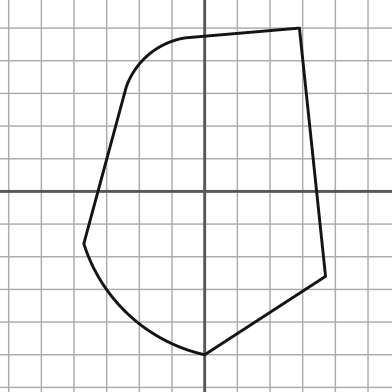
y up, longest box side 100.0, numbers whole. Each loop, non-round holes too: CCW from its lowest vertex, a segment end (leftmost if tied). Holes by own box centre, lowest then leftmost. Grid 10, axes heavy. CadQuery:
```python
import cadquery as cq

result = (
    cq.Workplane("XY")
    .moveTo(0.0, -50.0)
    .lineTo(37.0, -26.0)
    .lineTo(29.0, 50.0)
    .lineTo(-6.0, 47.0)
    .threePointArc((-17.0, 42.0), (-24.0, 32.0))
    .lineTo(-37.0, -16.0)
    .threePointArc((-23.0, -38.0), (0.0, -50.0))
    .close()
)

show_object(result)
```